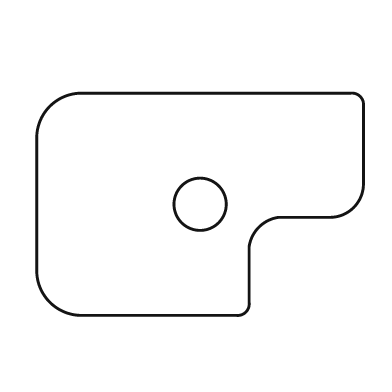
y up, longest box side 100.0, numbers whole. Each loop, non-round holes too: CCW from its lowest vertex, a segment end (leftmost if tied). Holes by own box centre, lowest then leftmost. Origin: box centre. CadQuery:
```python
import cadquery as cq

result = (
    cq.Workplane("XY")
    .moveTo(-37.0, -34.0)
    .lineTo(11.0, -34.0)
    .threePointArc((14.0, -33.0), (15.0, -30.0))
    .lineTo(15.0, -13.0)
    .threePointArc((18.0, -7.0), (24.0, -4.0))
    .lineTo(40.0, -4.0)
    .threePointArc((47.0, -1.0), (50.0, 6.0))
    .lineTo(50.0, 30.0)
    .threePointArc((49.0, 33.0), (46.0, 34.0))
    .lineTo(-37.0, 34.0)
    .threePointArc((-46.0, 30.0), (-50.0, 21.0))
    .lineTo(-50.0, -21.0)
    .threePointArc((-46.0, -30.0), (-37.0, -34.0))
    .close()
    .moveTo(0.0, 0.0)
    .circle(8.0)
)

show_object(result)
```